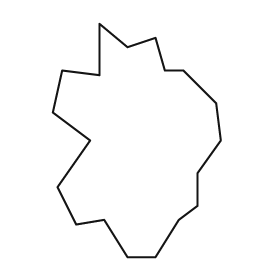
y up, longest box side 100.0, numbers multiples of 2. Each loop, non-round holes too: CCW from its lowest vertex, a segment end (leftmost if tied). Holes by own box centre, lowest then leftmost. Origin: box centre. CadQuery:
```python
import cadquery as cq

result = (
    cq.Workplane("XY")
    .moveTo(-4.0, -50.0)
    .lineTo(8.0, -50.0)
    .lineTo(18.0, -34.0)
    .lineTo(26.0, -28.0)
    .lineTo(26.0, -14.0)
    .lineTo(36.0, 0.0)
    .lineTo(34.0, 16.0)
    .lineTo(20.0, 30.0)
    .lineTo(12.0, 30.0)
    .lineTo(8.0, 44.0)
    .lineTo(-4.0, 40.0)
    .lineTo(-16.0, 50.0)
    .lineTo(-16.0, 28.0)
    .lineTo(-32.0, 30.0)
    .lineTo(-36.0, 12.0)
    .lineTo(-20.0, 0.0)
    .lineTo(-34.0, -20.0)
    .lineTo(-26.0, -36.0)
    .lineTo(-14.0, -34.0)
    .close()
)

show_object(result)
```